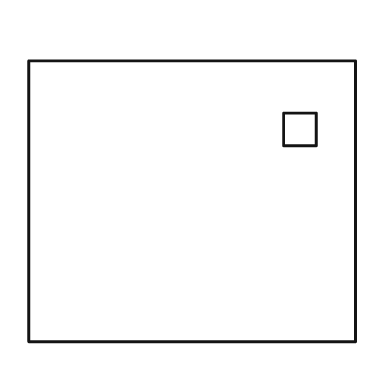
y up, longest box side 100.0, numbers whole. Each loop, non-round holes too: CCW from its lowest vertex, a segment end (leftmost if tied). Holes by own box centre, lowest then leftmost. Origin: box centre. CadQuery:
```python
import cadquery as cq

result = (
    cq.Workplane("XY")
    .moveTo(-50.0, -43.0)
    .lineTo(50.0, -43.0)
    .lineTo(50.0, 43.0)
    .lineTo(-50.0, 43.0)
    .close()
    .moveTo(28.0, 17.0)
    .lineTo(38.0, 17.0)
    .lineTo(38.0, 27.0)
    .lineTo(28.0, 27.0)
    .close()
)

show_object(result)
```